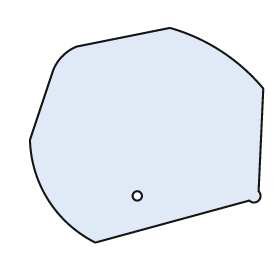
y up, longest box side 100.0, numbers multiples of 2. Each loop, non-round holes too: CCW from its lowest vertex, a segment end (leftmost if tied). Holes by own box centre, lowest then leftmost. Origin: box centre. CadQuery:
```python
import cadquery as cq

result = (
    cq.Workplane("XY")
    .moveTo(-22.0, -46.0)
    .lineTo(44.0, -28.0)
    .threePointArc((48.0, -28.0), (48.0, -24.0))
    .lineTo(50.0, 20.0)
    .threePointArc((32.0, 36.0), (10.0, 46.0))
    .lineTo(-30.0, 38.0)
    .threePointArc((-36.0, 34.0), (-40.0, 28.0))
    .lineTo(-50.0, -2.0)
    .threePointArc((-42.0, -28.0), (-22.0, -46.0))
    .close()
    .moveTo(-4.0, -26.0)
    .circle(2.0)
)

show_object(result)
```